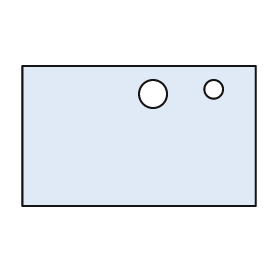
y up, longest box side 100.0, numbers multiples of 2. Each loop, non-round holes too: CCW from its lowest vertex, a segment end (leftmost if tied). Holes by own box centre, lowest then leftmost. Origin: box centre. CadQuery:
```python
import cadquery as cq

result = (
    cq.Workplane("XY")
    .moveTo(-50.0, -30.0)
    .lineTo(50.0, -30.0)
    .lineTo(50.0, 30.0)
    .lineTo(-50.0, 30.0)
    .close()
    .moveTo(6.0, 18.0)
    .circle(6.0)
    .moveTo(32.0, 20.0)
    .circle(4.0)
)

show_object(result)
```